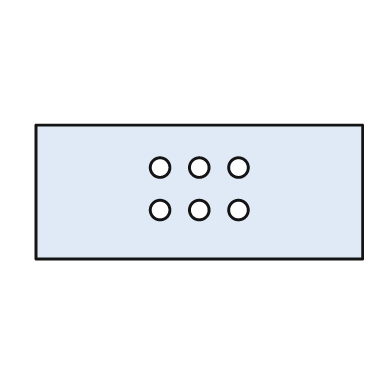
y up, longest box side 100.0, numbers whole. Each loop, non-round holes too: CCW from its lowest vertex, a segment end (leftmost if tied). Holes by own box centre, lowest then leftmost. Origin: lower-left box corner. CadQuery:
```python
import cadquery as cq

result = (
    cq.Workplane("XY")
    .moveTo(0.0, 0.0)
    .lineTo(100.0, 0.0)
    .lineTo(100.0, 41.0)
    .lineTo(0.0, 41.0)
    .close()
    .moveTo(38.0, 15.0)
    .circle(3.0)
    .moveTo(50.0, 15.0)
    .circle(3.0)
    .moveTo(62.0, 15.0)
    .circle(3.0)
    .moveTo(38.0, 28.0)
    .circle(3.0)
    .moveTo(50.0, 28.0)
    .circle(3.0)
    .moveTo(62.0, 28.0)
    .circle(3.0)
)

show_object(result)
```